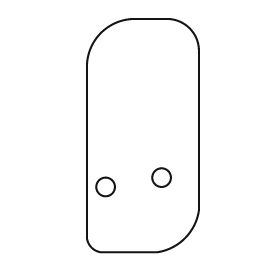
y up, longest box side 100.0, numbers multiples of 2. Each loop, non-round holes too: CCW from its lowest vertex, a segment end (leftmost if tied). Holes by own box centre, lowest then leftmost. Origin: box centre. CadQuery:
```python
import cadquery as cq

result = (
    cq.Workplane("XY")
    .moveTo(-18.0, -50.0)
    .lineTo(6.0, -50.0)
    .threePointArc((18.0, -44.0), (24.0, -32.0))
    .lineTo(24.0, 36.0)
    .threePointArc((20.0, 46.0), (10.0, 50.0))
    .lineTo(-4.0, 50.0)
    .threePointArc((-18.0, 44.0), (-24.0, 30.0))
    .lineTo(-24.0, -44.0)
    .threePointArc((-22.0, -48.0), (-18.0, -50.0))
    .close()
    .moveTo(-16.0, -22.0)
    .circle(4.0)
    .moveTo(8.0, -18.0)
    .circle(4.0)
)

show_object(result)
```